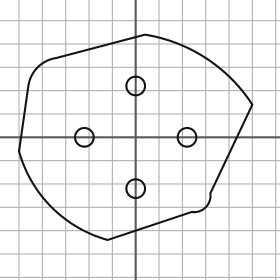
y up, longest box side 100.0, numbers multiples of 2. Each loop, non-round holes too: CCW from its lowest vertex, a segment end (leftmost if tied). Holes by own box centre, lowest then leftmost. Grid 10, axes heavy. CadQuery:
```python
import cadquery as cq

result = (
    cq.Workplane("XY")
    .moveTo(-12.0, -44.0)
    .lineTo(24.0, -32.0)
    .threePointArc((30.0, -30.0), (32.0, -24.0))
    .lineTo(50.0, 14.0)
    .threePointArc((30.0, 34.0), (4.0, 44.0))
    .lineTo(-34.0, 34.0)
    .threePointArc((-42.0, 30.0), (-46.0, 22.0))
    .lineTo(-50.0, -6.0)
    .threePointArc((-36.0, -30.0), (-12.0, -44.0))
    .close()
    .moveTo(0.0, -22.0)
    .circle(4.0)
    .moveTo(-22.0, 0.0)
    .circle(4.0)
    .moveTo(22.0, 0.0)
    .circle(4.0)
    .moveTo(0.0, 22.0)
    .circle(4.0)
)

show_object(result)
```